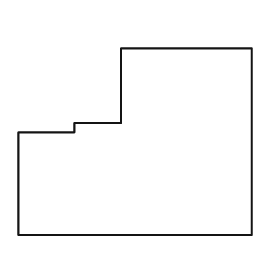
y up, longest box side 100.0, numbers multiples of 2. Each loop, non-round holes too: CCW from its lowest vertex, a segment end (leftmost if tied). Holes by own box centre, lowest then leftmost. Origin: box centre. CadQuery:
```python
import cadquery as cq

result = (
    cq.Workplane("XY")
    .moveTo(-50.0, -40.0)
    .lineTo(50.0, -40.0)
    .lineTo(50.0, 40.0)
    .lineTo(-6.0, 40.0)
    .lineTo(-6.0, 8.0)
    .lineTo(-26.0, 8.0)
    .lineTo(-26.0, 4.0)
    .lineTo(-50.0, 4.0)
    .close()
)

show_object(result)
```